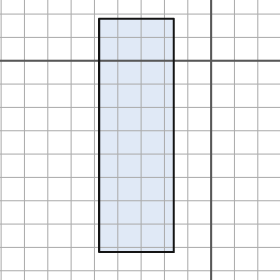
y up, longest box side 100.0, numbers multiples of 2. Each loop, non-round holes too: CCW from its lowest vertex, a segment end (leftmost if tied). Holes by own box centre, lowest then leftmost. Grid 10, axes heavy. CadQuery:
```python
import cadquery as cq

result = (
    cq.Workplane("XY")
    .moveTo(-48.0, -82.0)
    .lineTo(-16.0, -82.0)
    .lineTo(-16.0, 18.0)
    .lineTo(-48.0, 18.0)
    .close()
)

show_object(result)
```